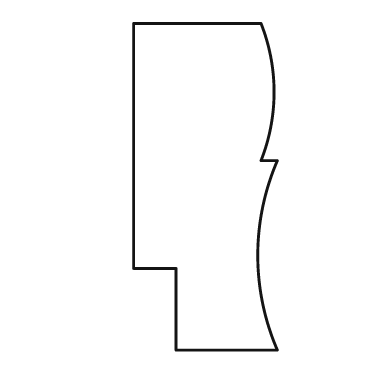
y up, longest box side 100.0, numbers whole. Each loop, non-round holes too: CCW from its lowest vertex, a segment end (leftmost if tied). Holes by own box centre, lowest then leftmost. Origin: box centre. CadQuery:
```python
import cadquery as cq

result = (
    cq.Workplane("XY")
    .moveTo(-9.0, -50.0)
    .lineTo(22.0, -50.0)
    .threePointArc((16.0, -21.0), (22.0, 8.0))
    .lineTo(17.0, 8.0)
    .threePointArc((21.0, 29.0), (17.0, 50.0))
    .lineTo(-22.0, 50.0)
    .lineTo(-22.0, -25.0)
    .lineTo(-9.0, -25.0)
    .close()
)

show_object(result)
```